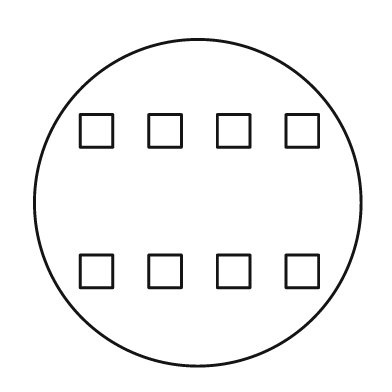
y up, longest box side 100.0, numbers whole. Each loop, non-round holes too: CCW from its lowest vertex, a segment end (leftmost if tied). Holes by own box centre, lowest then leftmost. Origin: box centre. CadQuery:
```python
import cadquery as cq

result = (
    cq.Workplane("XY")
    .moveTo(0.0, 0.0)
    .circle(50.0)
    .moveTo(-36.0, -26.0)
    .lineTo(-26.0, -26.0)
    .lineTo(-26.0, -16.0)
    .lineTo(-36.0, -16.0)
    .close()
    .moveTo(-15.0, -26.0)
    .lineTo(-5.0, -26.0)
    .lineTo(-5.0, -16.0)
    .lineTo(-15.0, -16.0)
    .close()
    .moveTo(6.0, -26.0)
    .lineTo(16.0, -26.0)
    .lineTo(16.0, -16.0)
    .lineTo(6.0, -16.0)
    .close()
    .moveTo(27.0, -26.0)
    .lineTo(37.0, -26.0)
    .lineTo(37.0, -16.0)
    .lineTo(27.0, -16.0)
    .close()
    .moveTo(-36.0, 17.0)
    .lineTo(-26.0, 17.0)
    .lineTo(-26.0, 27.0)
    .lineTo(-36.0, 27.0)
    .close()
    .moveTo(-15.0, 17.0)
    .lineTo(-5.0, 17.0)
    .lineTo(-5.0, 27.0)
    .lineTo(-15.0, 27.0)
    .close()
    .moveTo(6.0, 17.0)
    .lineTo(16.0, 17.0)
    .lineTo(16.0, 27.0)
    .lineTo(6.0, 27.0)
    .close()
    .moveTo(27.0, 17.0)
    .lineTo(37.0, 17.0)
    .lineTo(37.0, 27.0)
    .lineTo(27.0, 27.0)
    .close()
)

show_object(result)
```